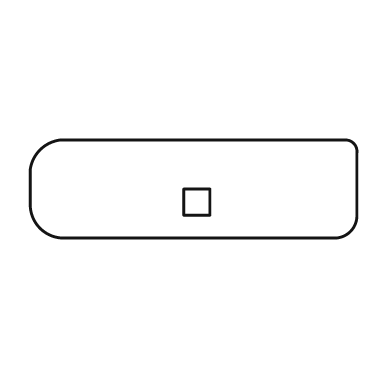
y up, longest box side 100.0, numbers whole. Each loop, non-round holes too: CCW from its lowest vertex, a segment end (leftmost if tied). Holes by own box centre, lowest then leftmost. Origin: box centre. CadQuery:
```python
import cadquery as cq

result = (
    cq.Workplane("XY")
    .moveTo(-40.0, -15.0)
    .lineTo(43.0, -15.0)
    .threePointArc((48.0, -13.0), (50.0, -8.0))
    .lineTo(50.0, 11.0)
    .threePointArc((49.0, 14.0), (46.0, 15.0))
    .lineTo(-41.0, 15.0)
    .threePointArc((-47.0, 12.0), (-50.0, 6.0))
    .lineTo(-50.0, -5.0)
    .threePointArc((-47.0, -12.0), (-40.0, -15.0))
    .close()
    .moveTo(-3.0, -8.0)
    .lineTo(5.0, -8.0)
    .lineTo(5.0, 0.0)
    .lineTo(-3.0, 0.0)
    .close()
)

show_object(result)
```